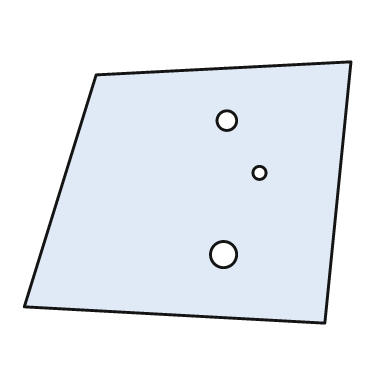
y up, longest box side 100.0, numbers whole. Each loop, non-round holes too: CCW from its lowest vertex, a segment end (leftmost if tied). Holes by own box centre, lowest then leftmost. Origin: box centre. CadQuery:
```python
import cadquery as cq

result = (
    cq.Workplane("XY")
    .moveTo(42.0, -40.0)
    .lineTo(50.0, 40.0)
    .lineTo(-28.0, 36.0)
    .lineTo(-50.0, -35.0)
    .close()
    .moveTo(11.0, -19.0)
    .circle(4.0)
    .moveTo(22.0, 6.0)
    .circle(2.0)
    .moveTo(12.0, 22.0)
    .circle(3.0)
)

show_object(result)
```